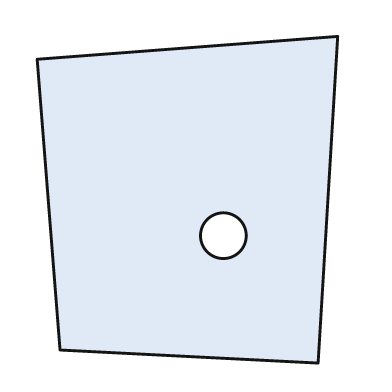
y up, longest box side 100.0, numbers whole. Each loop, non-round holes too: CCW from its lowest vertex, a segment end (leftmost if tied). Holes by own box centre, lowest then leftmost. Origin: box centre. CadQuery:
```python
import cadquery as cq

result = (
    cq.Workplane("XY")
    .moveTo(40.0, -50.0)
    .lineTo(46.0, 50.0)
    .lineTo(-46.0, 43.0)
    .lineTo(-39.0, -46.0)
    .close()
    .moveTo(11.0, -11.0)
    .circle(7.0)
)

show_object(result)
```